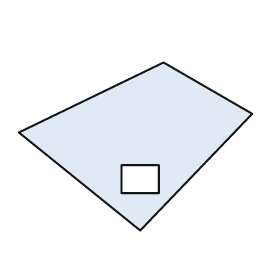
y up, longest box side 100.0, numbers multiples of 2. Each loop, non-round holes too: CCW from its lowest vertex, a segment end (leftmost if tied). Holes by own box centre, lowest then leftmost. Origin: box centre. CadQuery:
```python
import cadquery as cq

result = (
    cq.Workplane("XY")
    .moveTo(2.0, -36.0)
    .lineTo(50.0, 14.0)
    .lineTo(12.0, 36.0)
    .lineTo(-50.0, 6.0)
    .close()
    .moveTo(-6.0, -20.0)
    .lineTo(10.0, -20.0)
    .lineTo(10.0, -8.0)
    .lineTo(-6.0, -8.0)
    .close()
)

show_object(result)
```